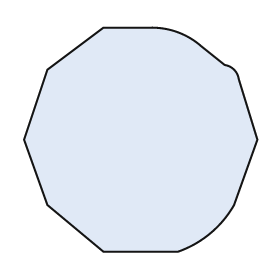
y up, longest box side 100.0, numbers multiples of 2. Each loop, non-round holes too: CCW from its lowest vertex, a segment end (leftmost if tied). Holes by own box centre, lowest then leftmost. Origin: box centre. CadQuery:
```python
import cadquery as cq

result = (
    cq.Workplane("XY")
    .moveTo(-16.0, -48.0)
    .lineTo(16.0, -48.0)
    .threePointArc((30.0, -40.0), (40.0, -28.0))
    .lineTo(50.0, 0.0)
    .lineTo(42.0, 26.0)
    .threePointArc((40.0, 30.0), (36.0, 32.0))
    .lineTo(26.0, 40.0)
    .threePointArc((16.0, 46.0), (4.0, 48.0))
    .lineTo(-16.0, 48.0)
    .lineTo(-40.0, 30.0)
    .lineTo(-50.0, 0.0)
    .lineTo(-40.0, -28.0)
    .close()
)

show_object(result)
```